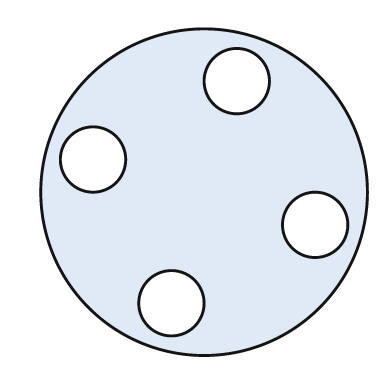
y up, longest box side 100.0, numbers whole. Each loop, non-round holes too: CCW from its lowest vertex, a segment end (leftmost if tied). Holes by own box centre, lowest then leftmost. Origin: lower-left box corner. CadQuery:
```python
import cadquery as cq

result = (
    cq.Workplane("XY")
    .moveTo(50.0, 50.0)
    .circle(50.0)
    .moveTo(40.0, 16.0)
    .circle(10.0)
    .moveTo(84.0, 40.0)
    .circle(10.0)
    .moveTo(16.0, 60.0)
    .circle(10.0)
    .moveTo(60.0, 84.0)
    .circle(10.0)
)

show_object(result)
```